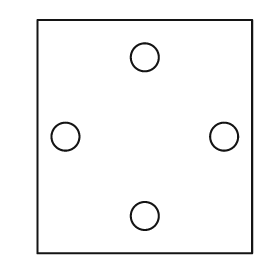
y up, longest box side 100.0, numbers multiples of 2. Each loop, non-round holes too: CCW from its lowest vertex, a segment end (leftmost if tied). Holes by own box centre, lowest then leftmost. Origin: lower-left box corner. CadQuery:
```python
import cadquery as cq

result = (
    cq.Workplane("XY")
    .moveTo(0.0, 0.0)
    .lineTo(92.0, 0.0)
    .lineTo(92.0, 100.0)
    .lineTo(0.0, 100.0)
    .close()
    .moveTo(46.0, 16.0)
    .circle(6.0)
    .moveTo(12.0, 50.0)
    .circle(6.0)
    .moveTo(80.0, 50.0)
    .circle(6.0)
    .moveTo(46.0, 84.0)
    .circle(6.0)
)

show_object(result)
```